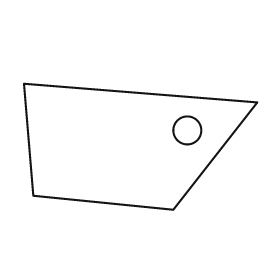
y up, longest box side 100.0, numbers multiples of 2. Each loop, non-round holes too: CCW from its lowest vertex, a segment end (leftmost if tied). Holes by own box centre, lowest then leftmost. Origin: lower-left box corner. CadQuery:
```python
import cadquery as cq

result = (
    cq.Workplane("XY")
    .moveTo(64.0, 0.0)
    .lineTo(100.0, 46.0)
    .lineTo(0.0, 54.0)
    .lineTo(4.0, 6.0)
    .close()
    .moveTo(70.0, 34.0)
    .circle(6.0)
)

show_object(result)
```